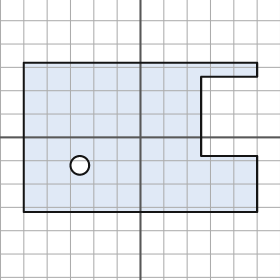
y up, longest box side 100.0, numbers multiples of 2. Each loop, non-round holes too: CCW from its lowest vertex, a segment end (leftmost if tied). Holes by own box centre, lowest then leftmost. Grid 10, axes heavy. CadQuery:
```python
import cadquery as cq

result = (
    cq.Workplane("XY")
    .moveTo(-50.0, -32.0)
    .lineTo(50.0, -32.0)
    .lineTo(50.0, -8.0)
    .lineTo(26.0, -8.0)
    .lineTo(26.0, 26.0)
    .lineTo(50.0, 26.0)
    .lineTo(50.0, 32.0)
    .lineTo(-50.0, 32.0)
    .close()
    .moveTo(-26.0, -12.0)
    .circle(4.0)
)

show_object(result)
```